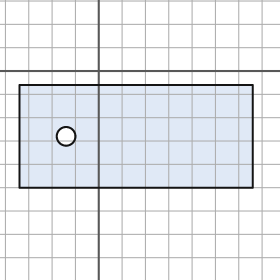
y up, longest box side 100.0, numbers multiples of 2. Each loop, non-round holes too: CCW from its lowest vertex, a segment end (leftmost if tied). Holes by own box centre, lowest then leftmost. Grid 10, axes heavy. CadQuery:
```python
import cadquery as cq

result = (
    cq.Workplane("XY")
    .moveTo(-34.0, -50.0)
    .lineTo(66.0, -50.0)
    .lineTo(66.0, -6.0)
    .lineTo(-34.0, -6.0)
    .close()
    .moveTo(-14.0, -28.0)
    .circle(4.0)
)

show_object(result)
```